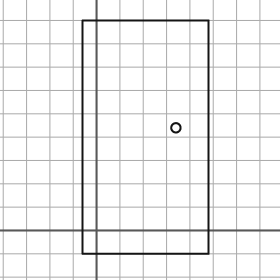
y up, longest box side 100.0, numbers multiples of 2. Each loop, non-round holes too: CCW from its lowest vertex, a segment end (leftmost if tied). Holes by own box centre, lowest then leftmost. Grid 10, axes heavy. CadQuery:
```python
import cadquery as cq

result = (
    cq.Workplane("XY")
    .moveTo(-6.0, -10.0)
    .lineTo(48.0, -10.0)
    .lineTo(48.0, 90.0)
    .lineTo(-6.0, 90.0)
    .close()
    .moveTo(34.0, 44.0)
    .circle(2.0)
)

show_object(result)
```